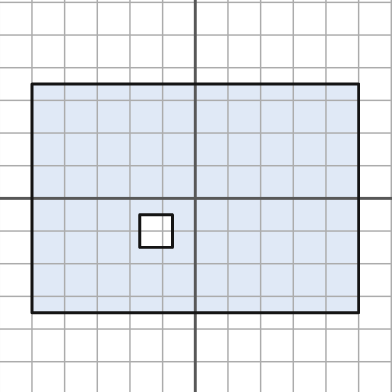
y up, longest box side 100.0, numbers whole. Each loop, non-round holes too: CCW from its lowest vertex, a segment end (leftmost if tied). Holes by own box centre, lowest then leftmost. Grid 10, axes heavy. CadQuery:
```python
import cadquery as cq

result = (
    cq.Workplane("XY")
    .moveTo(-50.0, -35.0)
    .lineTo(50.0, -35.0)
    .lineTo(50.0, 35.0)
    .lineTo(-50.0, 35.0)
    .close()
    .moveTo(-17.0, -15.0)
    .lineTo(-7.0, -15.0)
    .lineTo(-7.0, -5.0)
    .lineTo(-17.0, -5.0)
    .close()
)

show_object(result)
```